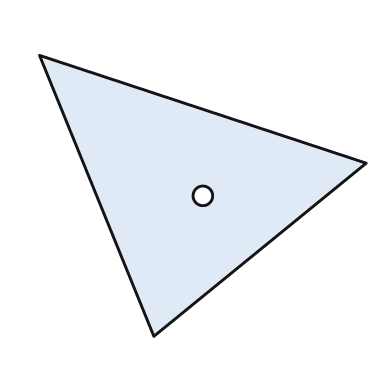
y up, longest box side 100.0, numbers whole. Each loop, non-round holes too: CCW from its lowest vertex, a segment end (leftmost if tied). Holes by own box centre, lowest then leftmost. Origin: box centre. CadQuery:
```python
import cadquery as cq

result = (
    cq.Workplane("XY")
    .moveTo(-15.0, -43.0)
    .lineTo(50.0, 10.0)
    .lineTo(-50.0, 43.0)
    .close()
    .moveTo(0.0, 0.0)
    .circle(3.0)
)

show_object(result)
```